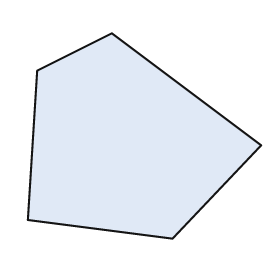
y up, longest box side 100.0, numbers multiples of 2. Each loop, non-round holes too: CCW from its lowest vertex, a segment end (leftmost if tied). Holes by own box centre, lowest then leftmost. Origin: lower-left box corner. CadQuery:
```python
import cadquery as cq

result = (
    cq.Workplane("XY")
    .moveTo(62.0, 0.0)
    .lineTo(100.0, 40.0)
    .lineTo(36.0, 88.0)
    .lineTo(4.0, 72.0)
    .lineTo(0.0, 8.0)
    .close()
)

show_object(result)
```